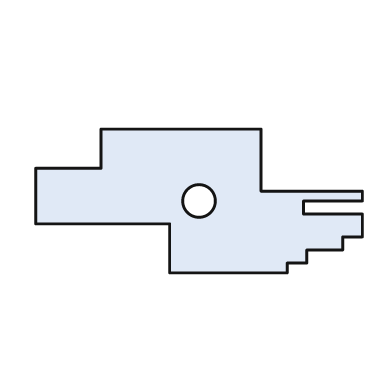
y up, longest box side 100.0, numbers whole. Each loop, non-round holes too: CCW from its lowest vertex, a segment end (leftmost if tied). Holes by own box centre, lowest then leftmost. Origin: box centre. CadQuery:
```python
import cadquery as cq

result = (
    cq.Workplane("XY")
    .moveTo(-9.0, -22.0)
    .lineTo(27.0, -22.0)
    .lineTo(27.0, -19.0)
    .lineTo(33.0, -19.0)
    .lineTo(33.0, -15.0)
    .lineTo(44.0, -15.0)
    .lineTo(44.0, -11.0)
    .lineTo(50.0, -11.0)
    .lineTo(50.0, -4.0)
    .lineTo(32.0, -4.0)
    .lineTo(32.0, 0.0)
    .lineTo(50.0, 0.0)
    .lineTo(50.0, 3.0)
    .lineTo(19.0, 3.0)
    .lineTo(19.0, 22.0)
    .lineTo(-30.0, 22.0)
    .lineTo(-30.0, 10.0)
    .lineTo(-50.0, 10.0)
    .lineTo(-50.0, -7.0)
    .lineTo(-9.0, -7.0)
    .close()
    .moveTo(0.0, 0.0)
    .circle(5.0)
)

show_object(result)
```